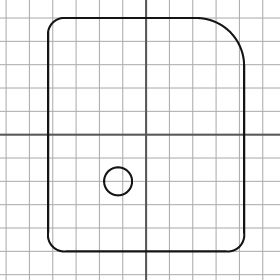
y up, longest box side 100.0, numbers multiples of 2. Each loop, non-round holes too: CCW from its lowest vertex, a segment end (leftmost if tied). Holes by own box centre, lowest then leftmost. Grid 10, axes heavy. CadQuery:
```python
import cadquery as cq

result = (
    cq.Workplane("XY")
    .moveTo(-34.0, -50.0)
    .lineTo(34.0, -50.0)
    .threePointArc((40.0, -48.0), (42.0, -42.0))
    .lineTo(42.0, 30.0)
    .threePointArc((36.0, 44.0), (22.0, 50.0))
    .lineTo(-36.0, 50.0)
    .threePointArc((-40.0, 48.0), (-42.0, 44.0))
    .lineTo(-42.0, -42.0)
    .threePointArc((-40.0, -48.0), (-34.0, -50.0))
    .close()
    .moveTo(-12.0, -20.0)
    .circle(6.0)
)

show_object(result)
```